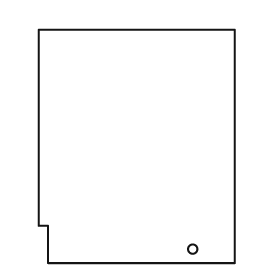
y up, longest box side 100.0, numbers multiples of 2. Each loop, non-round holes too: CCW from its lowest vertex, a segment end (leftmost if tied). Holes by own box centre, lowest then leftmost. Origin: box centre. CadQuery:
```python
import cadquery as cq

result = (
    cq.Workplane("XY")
    .moveTo(-38.0, -50.0)
    .lineTo(42.0, -50.0)
    .lineTo(42.0, 50.0)
    .lineTo(-42.0, 50.0)
    .lineTo(-42.0, -34.0)
    .lineTo(-38.0, -34.0)
    .close()
    .moveTo(24.0, -44.0)
    .circle(2.0)
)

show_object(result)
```